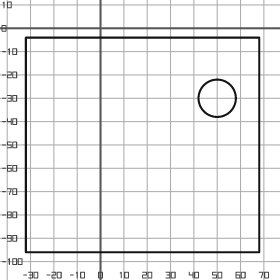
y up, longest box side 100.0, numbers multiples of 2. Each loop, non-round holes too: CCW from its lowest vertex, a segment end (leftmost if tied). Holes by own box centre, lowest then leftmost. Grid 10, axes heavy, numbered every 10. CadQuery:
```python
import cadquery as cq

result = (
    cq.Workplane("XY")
    .moveTo(-32.0, -96.0)
    .lineTo(68.0, -96.0)
    .lineTo(68.0, -4.0)
    .lineTo(-32.0, -4.0)
    .close()
    .moveTo(50.0, -30.0)
    .circle(8.0)
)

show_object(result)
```